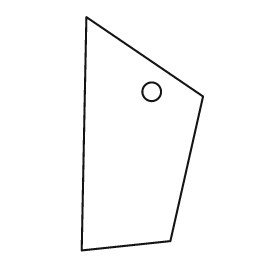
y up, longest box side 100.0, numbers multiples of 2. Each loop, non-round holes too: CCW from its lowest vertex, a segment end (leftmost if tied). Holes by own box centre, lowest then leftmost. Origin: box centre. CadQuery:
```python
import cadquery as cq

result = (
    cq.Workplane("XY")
    .moveTo(-26.0, -50.0)
    .lineTo(12.0, -46.0)
    .lineTo(26.0, 16.0)
    .lineTo(-24.0, 50.0)
    .close()
    .moveTo(4.0, 18.0)
    .circle(4.0)
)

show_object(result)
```